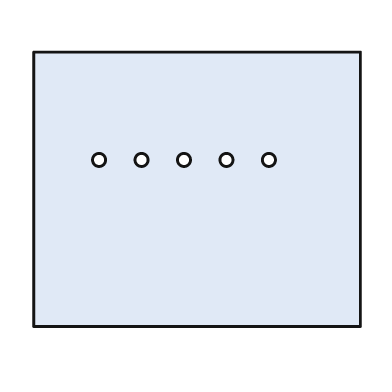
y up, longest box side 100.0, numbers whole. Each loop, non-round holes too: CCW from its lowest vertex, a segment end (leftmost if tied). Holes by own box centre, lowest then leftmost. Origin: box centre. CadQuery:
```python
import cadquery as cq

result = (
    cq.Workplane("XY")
    .moveTo(-50.0, -42.0)
    .lineTo(50.0, -42.0)
    .lineTo(50.0, 42.0)
    .lineTo(-50.0, 42.0)
    .close()
    .moveTo(-30.0, 9.0)
    .circle(2.0)
    .moveTo(-17.0, 9.0)
    .circle(2.0)
    .moveTo(-4.0, 9.0)
    .circle(2.0)
    .moveTo(9.0, 9.0)
    .circle(2.0)
    .moveTo(22.0, 9.0)
    .circle(2.0)
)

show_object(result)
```